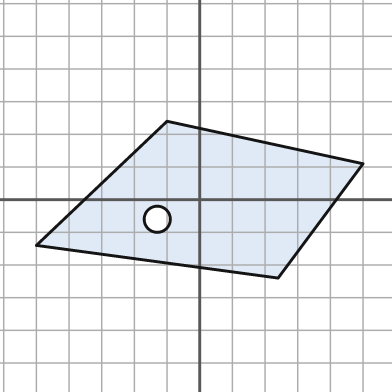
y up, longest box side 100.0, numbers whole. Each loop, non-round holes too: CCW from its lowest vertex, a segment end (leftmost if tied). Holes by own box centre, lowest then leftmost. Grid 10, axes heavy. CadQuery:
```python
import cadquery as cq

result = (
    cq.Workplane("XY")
    .moveTo(24.0, -24.0)
    .lineTo(50.0, 11.0)
    .lineTo(-10.0, 24.0)
    .lineTo(-50.0, -14.0)
    .close()
    .moveTo(-13.0, -6.0)
    .circle(4.0)
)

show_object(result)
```